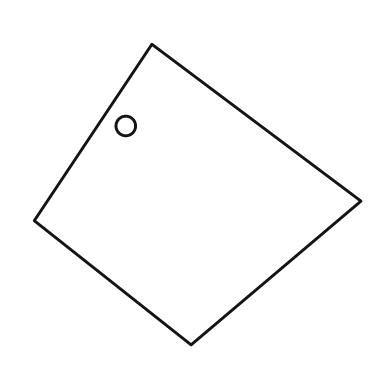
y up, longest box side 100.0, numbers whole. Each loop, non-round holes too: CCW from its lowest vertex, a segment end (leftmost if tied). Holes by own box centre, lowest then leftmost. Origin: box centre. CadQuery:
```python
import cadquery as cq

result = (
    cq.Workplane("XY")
    .moveTo(-2.0, -46.0)
    .lineTo(50.0, -2.0)
    .lineTo(-14.0, 46.0)
    .lineTo(-50.0, -8.0)
    .close()
    .moveTo(-22.0, 21.0)
    .circle(3.0)
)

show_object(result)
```